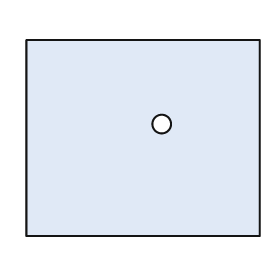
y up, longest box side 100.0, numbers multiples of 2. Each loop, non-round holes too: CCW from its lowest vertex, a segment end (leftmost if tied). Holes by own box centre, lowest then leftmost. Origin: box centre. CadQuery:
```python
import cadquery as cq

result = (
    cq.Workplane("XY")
    .moveTo(-50.0, -42.0)
    .lineTo(50.0, -42.0)
    .lineTo(50.0, 42.0)
    .lineTo(-50.0, 42.0)
    .close()
    .moveTo(8.0, 6.0)
    .circle(4.0)
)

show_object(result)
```